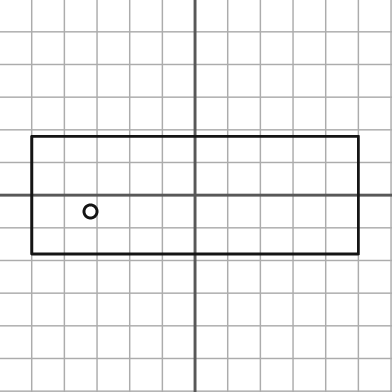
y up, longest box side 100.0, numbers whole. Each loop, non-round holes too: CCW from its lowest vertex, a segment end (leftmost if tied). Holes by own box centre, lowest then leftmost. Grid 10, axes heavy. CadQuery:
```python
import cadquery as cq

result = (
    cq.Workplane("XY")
    .moveTo(-50.0, -18.0)
    .lineTo(50.0, -18.0)
    .lineTo(50.0, 18.0)
    .lineTo(-50.0, 18.0)
    .close()
    .moveTo(-32.0, -5.0)
    .circle(2.0)
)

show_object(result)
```